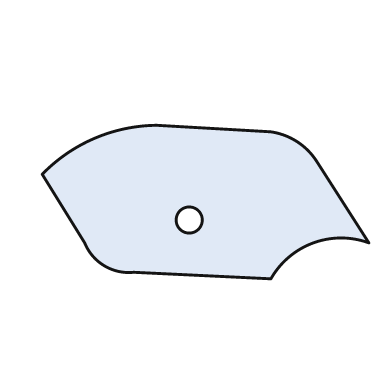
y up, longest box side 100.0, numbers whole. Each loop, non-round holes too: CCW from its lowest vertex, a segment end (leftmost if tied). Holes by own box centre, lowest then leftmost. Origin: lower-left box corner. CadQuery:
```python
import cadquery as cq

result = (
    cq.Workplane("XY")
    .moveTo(70.0, 0.0)
    .threePointArc((83.0, 11.0), (100.0, 11.0))
    .lineTo(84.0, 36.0)
    .threePointArc((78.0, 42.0), (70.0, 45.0))
    .lineTo(35.0, 47.0)
    .threePointArc((16.0, 43.0), (0.0, 32.0))
    .lineTo(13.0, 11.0)
    .threePointArc((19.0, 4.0), (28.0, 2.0))
    .close()
    .moveTo(45.0, 18.0)
    .circle(4.0)
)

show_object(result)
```